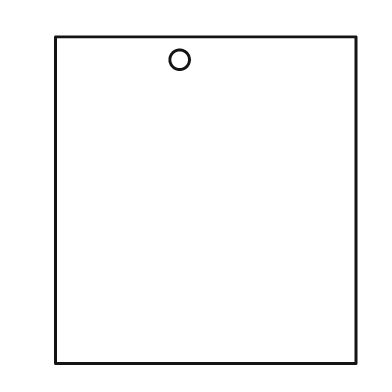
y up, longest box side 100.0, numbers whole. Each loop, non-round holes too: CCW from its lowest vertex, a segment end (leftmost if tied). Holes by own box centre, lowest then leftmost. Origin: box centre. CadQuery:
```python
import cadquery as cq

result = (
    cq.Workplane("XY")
    .moveTo(-46.0, -50.0)
    .lineTo(46.0, -50.0)
    .lineTo(46.0, 50.0)
    .lineTo(-46.0, 50.0)
    .close()
    .moveTo(-8.0, 43.0)
    .circle(3.0)
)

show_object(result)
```